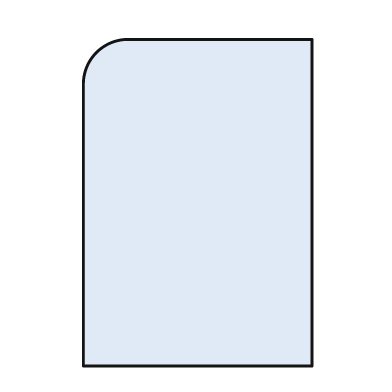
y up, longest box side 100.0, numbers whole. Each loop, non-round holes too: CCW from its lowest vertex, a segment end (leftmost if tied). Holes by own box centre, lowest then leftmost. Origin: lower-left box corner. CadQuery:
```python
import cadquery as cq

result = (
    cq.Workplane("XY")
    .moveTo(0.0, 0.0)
    .lineTo(70.0, 0.0)
    .lineTo(70.0, 100.0)
    .lineTo(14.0, 100.0)
    .threePointArc((4.0, 96.0), (0.0, 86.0))
    .close()
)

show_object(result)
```